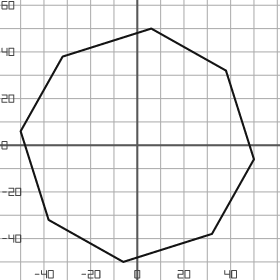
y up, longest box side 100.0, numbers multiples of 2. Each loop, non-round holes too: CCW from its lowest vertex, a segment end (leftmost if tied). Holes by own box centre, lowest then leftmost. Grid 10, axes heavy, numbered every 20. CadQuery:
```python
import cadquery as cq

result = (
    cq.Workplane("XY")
    .moveTo(-6.0, -50.0)
    .lineTo(32.0, -38.0)
    .lineTo(50.0, -6.0)
    .lineTo(38.0, 32.0)
    .lineTo(6.0, 50.0)
    .lineTo(-32.0, 38.0)
    .lineTo(-50.0, 6.0)
    .lineTo(-38.0, -32.0)
    .close()
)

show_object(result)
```